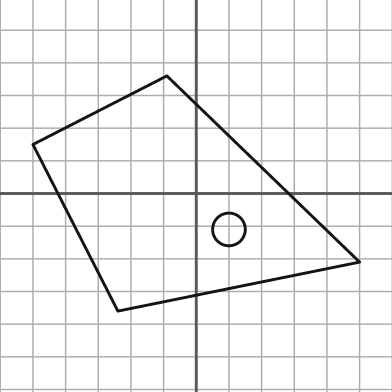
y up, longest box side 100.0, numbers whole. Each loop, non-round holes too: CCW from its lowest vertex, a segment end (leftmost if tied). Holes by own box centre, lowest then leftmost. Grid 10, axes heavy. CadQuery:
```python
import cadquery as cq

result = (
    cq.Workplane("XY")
    .moveTo(-24.0, -36.0)
    .lineTo(50.0, -21.0)
    .lineTo(-9.0, 36.0)
    .lineTo(-50.0, 15.0)
    .close()
    .moveTo(10.0, -11.0)
    .circle(5.0)
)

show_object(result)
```